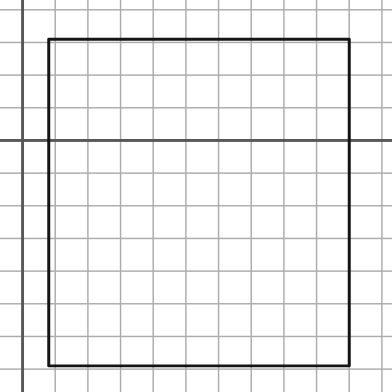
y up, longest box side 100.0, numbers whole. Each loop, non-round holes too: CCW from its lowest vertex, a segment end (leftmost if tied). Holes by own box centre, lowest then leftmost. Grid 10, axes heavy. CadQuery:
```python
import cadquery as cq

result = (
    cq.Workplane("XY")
    .moveTo(8.0, -69.0)
    .lineTo(100.0, -69.0)
    .lineTo(100.0, 31.0)
    .lineTo(8.0, 31.0)
    .close()
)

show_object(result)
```